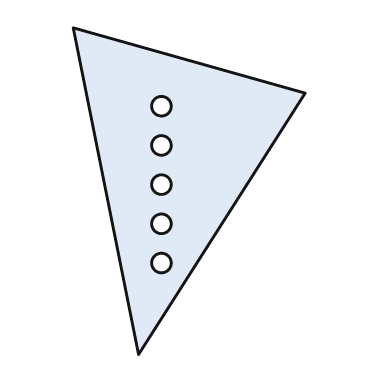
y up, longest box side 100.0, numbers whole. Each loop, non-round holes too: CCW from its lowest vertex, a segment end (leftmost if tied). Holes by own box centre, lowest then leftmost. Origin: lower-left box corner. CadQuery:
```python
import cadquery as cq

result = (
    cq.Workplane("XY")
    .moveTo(20.0, 0.0)
    .lineTo(71.0, 80.0)
    .lineTo(0.0, 100.0)
    .close()
    .moveTo(27.0, 28.0)
    .circle(3.0)
    .moveTo(27.0, 40.0)
    .circle(3.0)
    .moveTo(27.0, 52.0)
    .circle(3.0)
    .moveTo(27.0, 64.0)
    .circle(3.0)
    .moveTo(27.0, 76.0)
    .circle(3.0)
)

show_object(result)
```